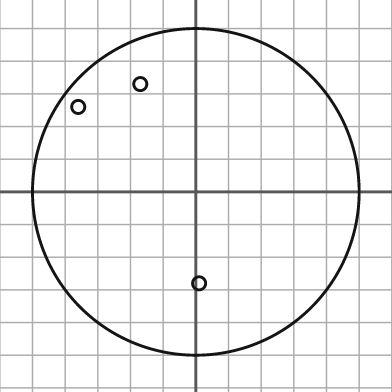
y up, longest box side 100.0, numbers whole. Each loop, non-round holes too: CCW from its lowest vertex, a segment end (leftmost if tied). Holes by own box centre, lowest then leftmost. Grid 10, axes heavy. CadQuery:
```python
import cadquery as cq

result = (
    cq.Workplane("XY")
    .moveTo(0.0, 0.0)
    .circle(50.0)
    .moveTo(1.0, -28.0)
    .circle(2.0)
    .moveTo(-36.0, 26.0)
    .circle(2.0)
    .moveTo(-17.0, 33.0)
    .circle(2.0)
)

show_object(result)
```